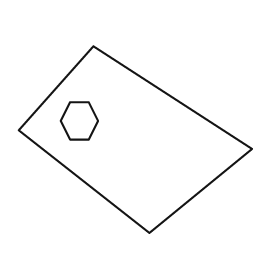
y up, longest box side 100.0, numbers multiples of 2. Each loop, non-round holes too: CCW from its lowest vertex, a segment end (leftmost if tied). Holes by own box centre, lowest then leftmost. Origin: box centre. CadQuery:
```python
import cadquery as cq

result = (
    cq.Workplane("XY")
    .moveTo(6.0, -40.0)
    .lineTo(50.0, -4.0)
    .lineTo(-18.0, 40.0)
    .lineTo(-50.0, 4.0)
    .close()
    .moveTo(-28.0, 0.0)
    .lineTo(-20.0, 0.0)
    .lineTo(-16.0, 8.0)
    .lineTo(-20.0, 16.0)
    .lineTo(-28.0, 16.0)
    .lineTo(-32.0, 8.0)
    .close()
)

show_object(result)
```